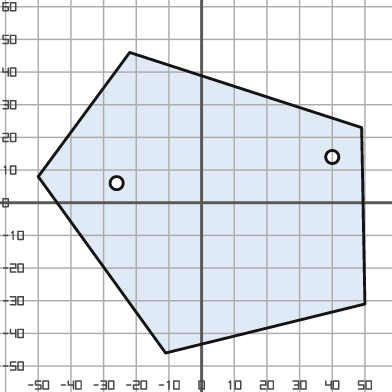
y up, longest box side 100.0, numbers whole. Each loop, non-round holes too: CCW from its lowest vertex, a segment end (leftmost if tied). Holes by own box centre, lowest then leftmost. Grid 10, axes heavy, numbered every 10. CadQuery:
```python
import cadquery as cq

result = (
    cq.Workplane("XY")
    .moveTo(-11.0, -46.0)
    .lineTo(50.0, -31.0)
    .lineTo(49.0, 23.0)
    .lineTo(-22.0, 46.0)
    .lineTo(-50.0, 8.0)
    .close()
    .moveTo(-26.0, 6.0)
    .circle(2.0)
    .moveTo(40.0, 14.0)
    .circle(2.0)
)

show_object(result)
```